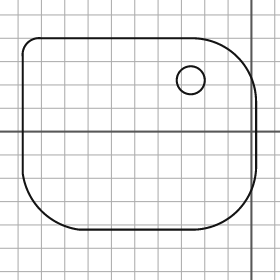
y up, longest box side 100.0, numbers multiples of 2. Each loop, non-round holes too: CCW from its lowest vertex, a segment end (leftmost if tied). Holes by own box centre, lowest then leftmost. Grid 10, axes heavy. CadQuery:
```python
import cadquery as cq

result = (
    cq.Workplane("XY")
    .moveTo(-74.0, -42.0)
    .lineTo(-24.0, -42.0)
    .threePointArc((-6.0, -34.0), (2.0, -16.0))
    .lineTo(2.0, 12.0)
    .threePointArc((-6.0, 32.0), (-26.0, 40.0))
    .lineTo(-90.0, 40.0)
    .threePointArc((-96.0, 38.0), (-98.0, 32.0))
    .lineTo(-98.0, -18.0)
    .threePointArc((-90.0, -34.0), (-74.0, -42.0))
    .close()
    .moveTo(-26.0, 22.0)
    .circle(6.0)
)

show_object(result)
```